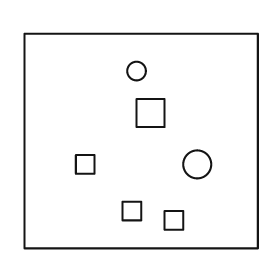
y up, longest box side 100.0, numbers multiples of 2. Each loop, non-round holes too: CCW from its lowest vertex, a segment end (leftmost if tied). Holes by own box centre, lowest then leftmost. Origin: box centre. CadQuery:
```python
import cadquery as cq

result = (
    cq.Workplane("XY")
    .moveTo(-50.0, -46.0)
    .lineTo(50.0, -46.0)
    .lineTo(50.0, 46.0)
    .lineTo(-50.0, 46.0)
    .close()
    .moveTo(10.0, -38.0)
    .lineTo(18.0, -38.0)
    .lineTo(18.0, -30.0)
    .lineTo(10.0, -30.0)
    .close()
    .moveTo(-8.0, -34.0)
    .lineTo(0.0, -34.0)
    .lineTo(0.0, -26.0)
    .lineTo(-8.0, -26.0)
    .close()
    .moveTo(-28.0, -14.0)
    .lineTo(-20.0, -14.0)
    .lineTo(-20.0, -6.0)
    .lineTo(-28.0, -6.0)
    .close()
    .moveTo(24.0, -10.0)
    .circle(6.0)
    .moveTo(-2.0, 6.0)
    .lineTo(10.0, 6.0)
    .lineTo(10.0, 18.0)
    .lineTo(-2.0, 18.0)
    .close()
    .moveTo(-2.0, 30.0)
    .circle(4.0)
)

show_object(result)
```